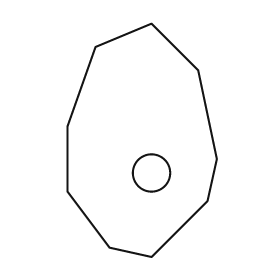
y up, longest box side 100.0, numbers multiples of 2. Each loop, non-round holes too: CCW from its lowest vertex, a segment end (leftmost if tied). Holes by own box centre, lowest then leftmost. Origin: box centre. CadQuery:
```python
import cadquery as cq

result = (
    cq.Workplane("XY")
    .moveTo(4.0, -50.0)
    .lineTo(28.0, -26.0)
    .lineTo(32.0, -8.0)
    .lineTo(24.0, 30.0)
    .lineTo(4.0, 50.0)
    .lineTo(-20.0, 40.0)
    .lineTo(-32.0, 6.0)
    .lineTo(-32.0, -22.0)
    .lineTo(-14.0, -46.0)
    .close()
    .moveTo(4.0, -14.0)
    .circle(8.0)
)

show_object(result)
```